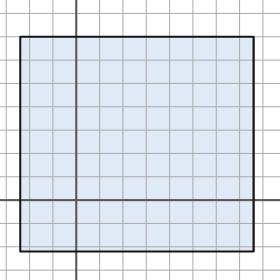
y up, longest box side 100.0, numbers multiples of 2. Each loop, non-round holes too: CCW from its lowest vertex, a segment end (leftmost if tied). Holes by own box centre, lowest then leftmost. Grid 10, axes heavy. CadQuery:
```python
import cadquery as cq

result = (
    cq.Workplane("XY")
    .moveTo(-24.0, -22.0)
    .lineTo(76.0, -22.0)
    .lineTo(76.0, 70.0)
    .lineTo(-24.0, 70.0)
    .close()
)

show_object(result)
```